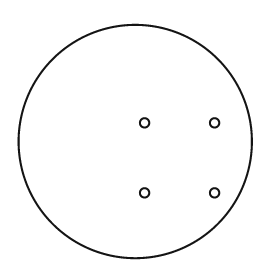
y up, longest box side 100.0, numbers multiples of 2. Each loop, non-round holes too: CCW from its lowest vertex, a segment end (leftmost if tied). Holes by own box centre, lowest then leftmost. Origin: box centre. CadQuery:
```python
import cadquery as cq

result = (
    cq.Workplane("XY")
    .moveTo(0.0, 0.0)
    .circle(50.0)
    .moveTo(4.0, -22.0)
    .circle(2.0)
    .moveTo(34.0, -22.0)
    .circle(2.0)
    .moveTo(4.0, 8.0)
    .circle(2.0)
    .moveTo(34.0, 8.0)
    .circle(2.0)
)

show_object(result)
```